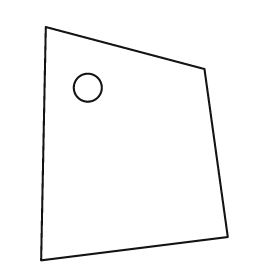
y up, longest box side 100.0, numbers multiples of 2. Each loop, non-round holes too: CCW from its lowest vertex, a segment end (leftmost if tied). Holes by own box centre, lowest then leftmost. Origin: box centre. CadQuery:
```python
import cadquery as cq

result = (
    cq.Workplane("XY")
    .moveTo(-40.0, -50.0)
    .lineTo(40.0, -40.0)
    .lineTo(30.0, 32.0)
    .lineTo(-38.0, 50.0)
    .close()
    .moveTo(-20.0, 24.0)
    .circle(6.0)
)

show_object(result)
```